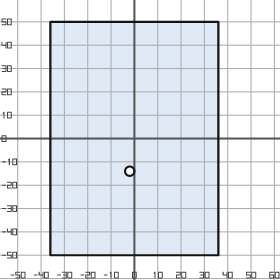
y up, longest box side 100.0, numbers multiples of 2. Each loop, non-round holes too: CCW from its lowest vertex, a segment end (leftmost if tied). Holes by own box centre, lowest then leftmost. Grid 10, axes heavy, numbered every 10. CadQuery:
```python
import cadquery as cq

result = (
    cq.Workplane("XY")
    .moveTo(-36.0, -50.0)
    .lineTo(36.0, -50.0)
    .lineTo(36.0, 50.0)
    .lineTo(-36.0, 50.0)
    .close()
    .moveTo(-2.0, -14.0)
    .circle(2.0)
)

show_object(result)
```